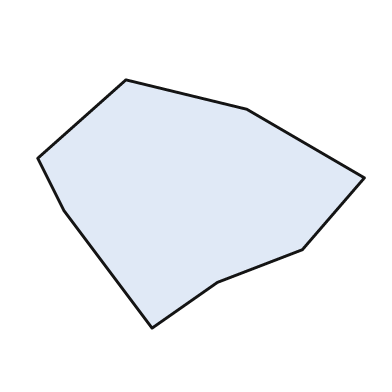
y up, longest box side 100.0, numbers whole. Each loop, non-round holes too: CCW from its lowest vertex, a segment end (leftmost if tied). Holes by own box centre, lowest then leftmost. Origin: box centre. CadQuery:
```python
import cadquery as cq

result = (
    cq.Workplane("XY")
    .moveTo(-15.0, -38.0)
    .lineTo(5.0, -24.0)
    .lineTo(31.0, -14.0)
    .lineTo(50.0, 8.0)
    .lineTo(14.0, 29.0)
    .lineTo(-23.0, 38.0)
    .lineTo(-50.0, 14.0)
    .lineTo(-42.0, -2.0)
    .close()
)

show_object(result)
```